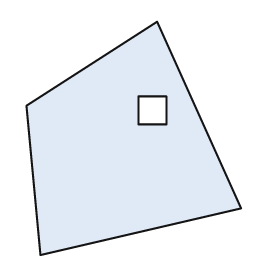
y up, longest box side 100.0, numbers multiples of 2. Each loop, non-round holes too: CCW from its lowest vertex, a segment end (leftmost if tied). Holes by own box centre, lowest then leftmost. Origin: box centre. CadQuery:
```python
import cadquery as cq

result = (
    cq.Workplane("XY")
    .moveTo(-40.0, -50.0)
    .lineTo(46.0, -30.0)
    .lineTo(10.0, 50.0)
    .lineTo(-46.0, 14.0)
    .close()
    .moveTo(2.0, 6.0)
    .lineTo(14.0, 6.0)
    .lineTo(14.0, 18.0)
    .lineTo(2.0, 18.0)
    .close()
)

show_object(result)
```